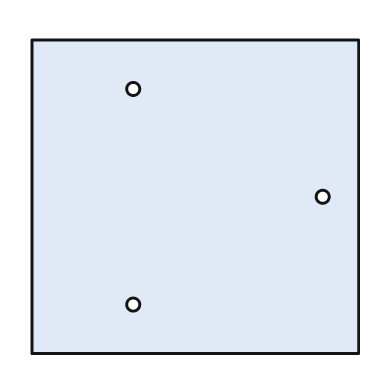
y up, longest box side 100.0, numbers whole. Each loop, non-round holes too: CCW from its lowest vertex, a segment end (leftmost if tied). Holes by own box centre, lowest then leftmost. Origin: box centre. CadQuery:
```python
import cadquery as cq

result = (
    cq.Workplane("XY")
    .moveTo(-50.0, -48.0)
    .lineTo(50.0, -48.0)
    .lineTo(50.0, 48.0)
    .lineTo(-50.0, 48.0)
    .close()
    .moveTo(-19.0, -33.0)
    .circle(2.0)
    .moveTo(39.0, 0.0)
    .circle(2.0)
    .moveTo(-19.0, 33.0)
    .circle(2.0)
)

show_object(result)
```